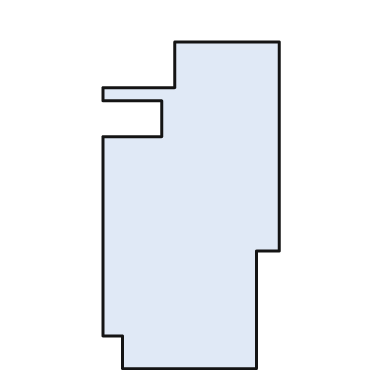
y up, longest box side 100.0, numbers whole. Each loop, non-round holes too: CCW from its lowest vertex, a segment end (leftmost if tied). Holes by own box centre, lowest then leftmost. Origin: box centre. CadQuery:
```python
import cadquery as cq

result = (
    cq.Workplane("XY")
    .moveTo(-21.0, -50.0)
    .lineTo(20.0, -50.0)
    .lineTo(20.0, -14.0)
    .lineTo(27.0, -14.0)
    .lineTo(27.0, 50.0)
    .lineTo(-5.0, 50.0)
    .lineTo(-5.0, 36.0)
    .lineTo(-27.0, 36.0)
    .lineTo(-27.0, 32.0)
    .lineTo(-9.0, 32.0)
    .lineTo(-9.0, 21.0)
    .lineTo(-27.0, 21.0)
    .lineTo(-27.0, -40.0)
    .lineTo(-21.0, -40.0)
    .close()
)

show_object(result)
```